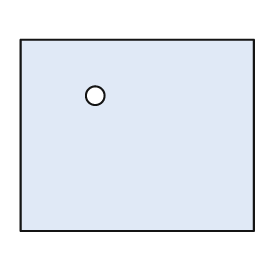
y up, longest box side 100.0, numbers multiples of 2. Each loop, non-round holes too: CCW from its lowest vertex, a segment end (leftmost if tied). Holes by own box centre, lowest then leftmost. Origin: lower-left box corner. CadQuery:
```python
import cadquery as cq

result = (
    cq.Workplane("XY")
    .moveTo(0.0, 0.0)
    .lineTo(100.0, 0.0)
    .lineTo(100.0, 82.0)
    .lineTo(0.0, 82.0)
    .close()
    .moveTo(32.0, 58.0)
    .circle(4.0)
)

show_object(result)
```